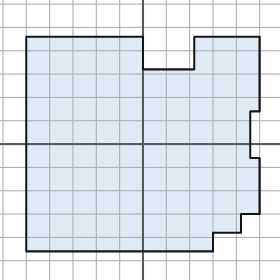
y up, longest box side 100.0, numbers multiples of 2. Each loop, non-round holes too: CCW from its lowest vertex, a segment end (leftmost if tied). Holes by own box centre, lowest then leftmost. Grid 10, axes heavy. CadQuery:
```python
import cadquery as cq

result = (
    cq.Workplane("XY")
    .moveTo(-50.0, -46.0)
    .lineTo(30.0, -46.0)
    .lineTo(30.0, -38.0)
    .lineTo(42.0, -38.0)
    .lineTo(42.0, -30.0)
    .lineTo(50.0, -30.0)
    .lineTo(50.0, -6.0)
    .lineTo(46.0, -6.0)
    .lineTo(46.0, 14.0)
    .lineTo(50.0, 14.0)
    .lineTo(50.0, 46.0)
    .lineTo(22.0, 46.0)
    .lineTo(22.0, 32.0)
    .lineTo(0.0, 32.0)
    .lineTo(0.0, 46.0)
    .lineTo(-50.0, 46.0)
    .close()
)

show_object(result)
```